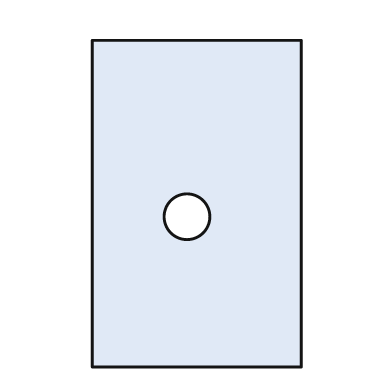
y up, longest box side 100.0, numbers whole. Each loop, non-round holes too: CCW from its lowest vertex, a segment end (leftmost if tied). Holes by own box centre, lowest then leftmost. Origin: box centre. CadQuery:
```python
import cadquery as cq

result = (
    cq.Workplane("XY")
    .moveTo(-32.0, -50.0)
    .lineTo(32.0, -50.0)
    .lineTo(32.0, 50.0)
    .lineTo(-32.0, 50.0)
    .close()
    .moveTo(-3.0, -4.0)
    .circle(7.0)
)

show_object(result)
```